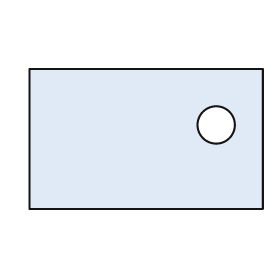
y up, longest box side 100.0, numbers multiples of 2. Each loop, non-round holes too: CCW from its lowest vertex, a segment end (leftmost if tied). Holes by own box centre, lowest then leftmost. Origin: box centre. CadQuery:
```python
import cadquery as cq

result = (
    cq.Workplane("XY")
    .moveTo(-50.0, -30.0)
    .lineTo(50.0, -30.0)
    .lineTo(50.0, 30.0)
    .lineTo(-50.0, 30.0)
    .close()
    .moveTo(30.0, 6.0)
    .circle(8.0)
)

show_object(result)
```